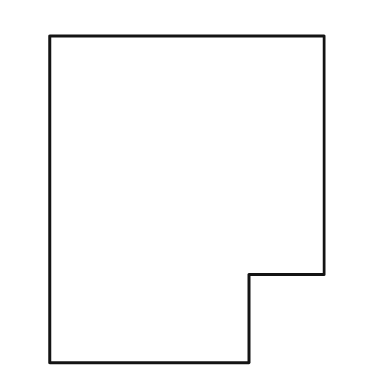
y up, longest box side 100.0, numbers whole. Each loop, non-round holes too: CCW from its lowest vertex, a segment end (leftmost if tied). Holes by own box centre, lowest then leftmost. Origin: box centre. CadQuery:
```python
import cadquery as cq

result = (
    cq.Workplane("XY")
    .moveTo(-42.0, -50.0)
    .lineTo(19.0, -50.0)
    .lineTo(19.0, -23.0)
    .lineTo(42.0, -23.0)
    .lineTo(42.0, 50.0)
    .lineTo(-42.0, 50.0)
    .close()
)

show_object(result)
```